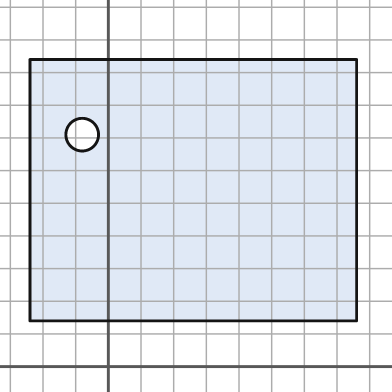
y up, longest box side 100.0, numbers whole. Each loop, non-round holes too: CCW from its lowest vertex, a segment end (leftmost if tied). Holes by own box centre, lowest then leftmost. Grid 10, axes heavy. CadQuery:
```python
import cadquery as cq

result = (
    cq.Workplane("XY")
    .moveTo(-24.0, 14.0)
    .lineTo(76.0, 14.0)
    .lineTo(76.0, 94.0)
    .lineTo(-24.0, 94.0)
    .close()
    .moveTo(-8.0, 71.0)
    .circle(5.0)
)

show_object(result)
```